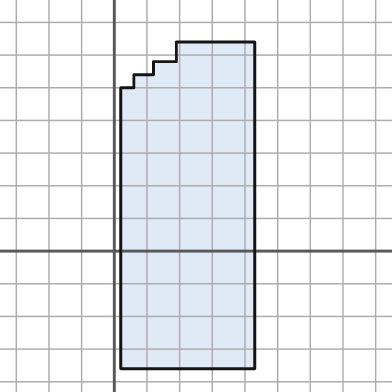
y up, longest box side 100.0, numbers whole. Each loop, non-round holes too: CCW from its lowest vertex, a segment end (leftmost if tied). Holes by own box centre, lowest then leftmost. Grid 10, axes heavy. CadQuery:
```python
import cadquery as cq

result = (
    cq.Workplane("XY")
    .moveTo(2.0, -36.0)
    .lineTo(43.0, -36.0)
    .lineTo(43.0, 64.0)
    .lineTo(19.0, 64.0)
    .lineTo(19.0, 58.0)
    .lineTo(12.0, 58.0)
    .lineTo(12.0, 54.0)
    .lineTo(6.0, 54.0)
    .lineTo(6.0, 50.0)
    .lineTo(2.0, 50.0)
    .close()
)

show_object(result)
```